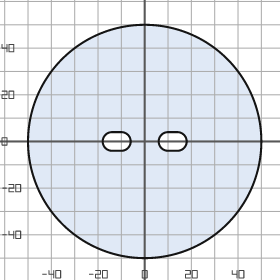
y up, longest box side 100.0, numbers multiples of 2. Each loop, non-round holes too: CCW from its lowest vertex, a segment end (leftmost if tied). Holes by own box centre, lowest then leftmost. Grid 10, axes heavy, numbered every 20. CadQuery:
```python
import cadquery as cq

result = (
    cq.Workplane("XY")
    .moveTo(0.0, 0.0)
    .circle(50.0)
    .moveTo(-14.0, -4.0)
    .lineTo(-10.0, -4.0)
    .threePointArc((-6.0, 0.0), (-10.0, 4.0))
    .lineTo(-14.0, 4.0)
    .threePointArc((-18.0, 0.0), (-14.0, -4.0))
    .close()
    .moveTo(10.0, -4.0)
    .lineTo(14.0, -4.0)
    .threePointArc((18.0, 0.0), (14.0, 4.0))
    .lineTo(10.0, 4.0)
    .threePointArc((6.0, 0.0), (10.0, -4.0))
    .close()
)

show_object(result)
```